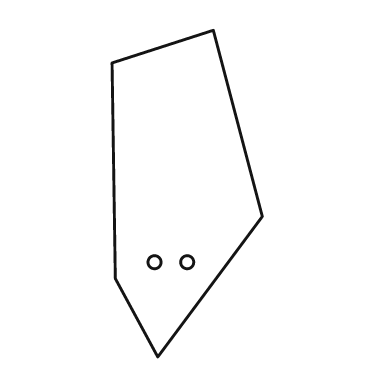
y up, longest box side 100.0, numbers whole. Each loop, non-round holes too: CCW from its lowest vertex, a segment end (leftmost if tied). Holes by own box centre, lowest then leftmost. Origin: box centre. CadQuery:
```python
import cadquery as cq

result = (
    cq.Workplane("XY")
    .moveTo(-9.0, -50.0)
    .lineTo(23.0, -7.0)
    .lineTo(8.0, 50.0)
    .lineTo(-23.0, 40.0)
    .lineTo(-22.0, -26.0)
    .close()
    .moveTo(-10.0, -21.0)
    .circle(2.0)
    .moveTo(0.0, -21.0)
    .circle(2.0)
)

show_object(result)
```